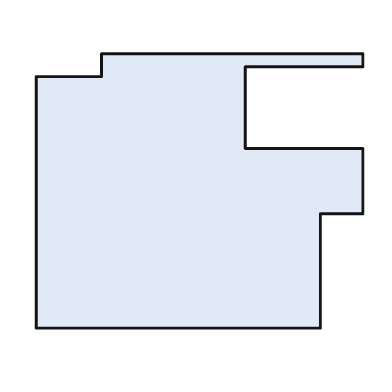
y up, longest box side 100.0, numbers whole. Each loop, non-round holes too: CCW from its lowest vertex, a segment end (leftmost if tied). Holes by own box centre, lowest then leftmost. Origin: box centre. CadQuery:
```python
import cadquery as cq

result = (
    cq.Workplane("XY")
    .moveTo(-50.0, -42.0)
    .lineTo(37.0, -42.0)
    .lineTo(37.0, -7.0)
    .lineTo(50.0, -7.0)
    .lineTo(50.0, 13.0)
    .lineTo(14.0, 13.0)
    .lineTo(14.0, 38.0)
    .lineTo(50.0, 38.0)
    .lineTo(50.0, 42.0)
    .lineTo(-30.0, 42.0)
    .lineTo(-30.0, 35.0)
    .lineTo(-50.0, 35.0)
    .close()
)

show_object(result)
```